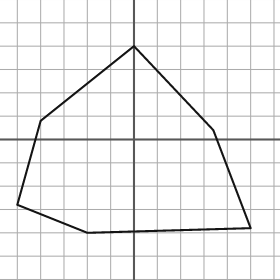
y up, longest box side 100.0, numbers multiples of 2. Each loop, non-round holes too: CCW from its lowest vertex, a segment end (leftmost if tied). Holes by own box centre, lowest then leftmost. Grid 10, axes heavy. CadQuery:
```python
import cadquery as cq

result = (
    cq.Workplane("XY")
    .moveTo(-20.0, -40.0)
    .lineTo(50.0, -38.0)
    .lineTo(34.0, 4.0)
    .lineTo(0.0, 40.0)
    .lineTo(-40.0, 8.0)
    .lineTo(-50.0, -28.0)
    .close()
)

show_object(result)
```